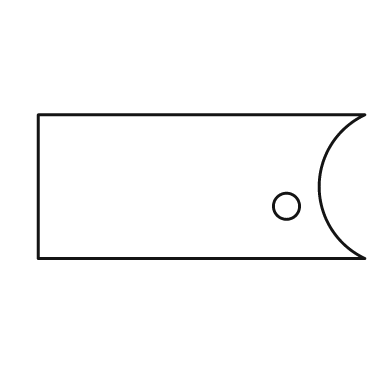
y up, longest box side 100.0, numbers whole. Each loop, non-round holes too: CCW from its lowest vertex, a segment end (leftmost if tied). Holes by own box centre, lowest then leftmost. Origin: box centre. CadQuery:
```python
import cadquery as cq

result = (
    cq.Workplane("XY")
    .moveTo(-50.0, -22.0)
    .lineTo(50.0, -22.0)
    .threePointArc((36.0, 0.0), (50.0, 22.0))
    .lineTo(-50.0, 22.0)
    .close()
    .moveTo(26.0, -6.0)
    .circle(4.0)
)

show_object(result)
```